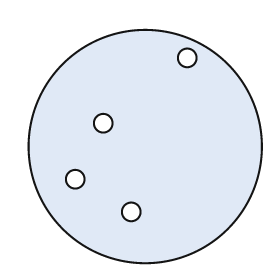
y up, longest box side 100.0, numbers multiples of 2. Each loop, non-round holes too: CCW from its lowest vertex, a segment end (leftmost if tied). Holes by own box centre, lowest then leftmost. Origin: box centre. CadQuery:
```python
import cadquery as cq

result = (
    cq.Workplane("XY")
    .moveTo(0.0, 0.0)
    .circle(50.0)
    .moveTo(-6.0, -28.0)
    .circle(4.0)
    .moveTo(-30.0, -14.0)
    .circle(4.0)
    .moveTo(-18.0, 10.0)
    .circle(4.0)
    .moveTo(18.0, 38.0)
    .circle(4.0)
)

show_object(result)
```